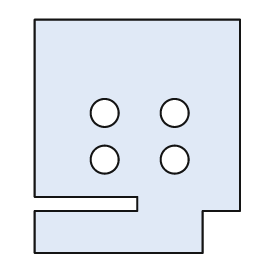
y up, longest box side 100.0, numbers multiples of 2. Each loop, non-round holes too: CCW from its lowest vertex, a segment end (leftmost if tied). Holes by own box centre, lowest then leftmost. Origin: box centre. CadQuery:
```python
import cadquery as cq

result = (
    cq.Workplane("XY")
    .moveTo(-44.0, -50.0)
    .lineTo(28.0, -50.0)
    .lineTo(28.0, -32.0)
    .lineTo(44.0, -32.0)
    .lineTo(44.0, 50.0)
    .lineTo(-44.0, 50.0)
    .lineTo(-44.0, -26.0)
    .lineTo(0.0, -26.0)
    .lineTo(0.0, -32.0)
    .lineTo(-44.0, -32.0)
    .close()
    .moveTo(-14.0, -10.0)
    .circle(6.0)
    .moveTo(16.0, -10.0)
    .circle(6.0)
    .moveTo(-14.0, 10.0)
    .circle(6.0)
    .moveTo(16.0, 10.0)
    .circle(6.0)
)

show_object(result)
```